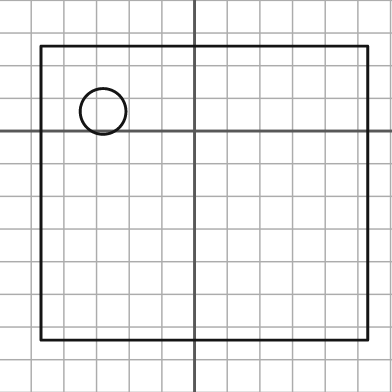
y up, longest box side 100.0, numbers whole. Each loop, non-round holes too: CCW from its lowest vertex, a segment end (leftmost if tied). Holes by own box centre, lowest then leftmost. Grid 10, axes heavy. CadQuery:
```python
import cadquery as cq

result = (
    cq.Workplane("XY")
    .moveTo(-47.0, -64.0)
    .lineTo(53.0, -64.0)
    .lineTo(53.0, 26.0)
    .lineTo(-47.0, 26.0)
    .close()
    .moveTo(-28.0, 6.0)
    .circle(7.0)
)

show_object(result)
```